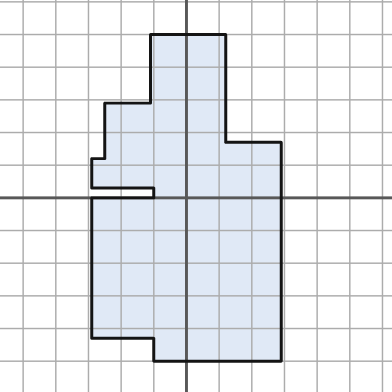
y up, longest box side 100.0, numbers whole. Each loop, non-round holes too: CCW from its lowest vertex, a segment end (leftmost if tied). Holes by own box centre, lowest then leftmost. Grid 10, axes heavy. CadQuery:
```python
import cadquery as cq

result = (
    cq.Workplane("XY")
    .moveTo(-10.0, -50.0)
    .lineTo(29.0, -50.0)
    .lineTo(29.0, 17.0)
    .lineTo(12.0, 17.0)
    .lineTo(12.0, 50.0)
    .lineTo(-11.0, 50.0)
    .lineTo(-11.0, 29.0)
    .lineTo(-25.0, 29.0)
    .lineTo(-25.0, 12.0)
    .lineTo(-29.0, 12.0)
    .lineTo(-29.0, 3.0)
    .lineTo(-10.0, 3.0)
    .lineTo(-10.0, 0.0)
    .lineTo(-29.0, 0.0)
    .lineTo(-29.0, -43.0)
    .lineTo(-10.0, -43.0)
    .close()
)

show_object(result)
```